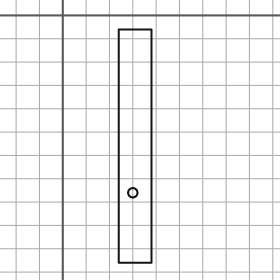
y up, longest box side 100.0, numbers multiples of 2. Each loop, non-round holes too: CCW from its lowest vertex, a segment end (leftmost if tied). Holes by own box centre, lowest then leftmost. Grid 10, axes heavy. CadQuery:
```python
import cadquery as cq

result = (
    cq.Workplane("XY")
    .moveTo(24.0, -106.0)
    .lineTo(38.0, -106.0)
    .lineTo(38.0, -6.0)
    .lineTo(24.0, -6.0)
    .close()
    .moveTo(30.0, -76.0)
    .circle(2.0)
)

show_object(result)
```